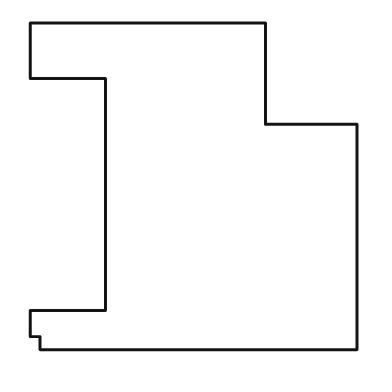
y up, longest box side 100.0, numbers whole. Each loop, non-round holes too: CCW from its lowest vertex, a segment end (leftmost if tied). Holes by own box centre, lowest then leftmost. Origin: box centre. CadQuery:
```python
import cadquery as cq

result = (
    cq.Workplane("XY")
    .moveTo(-47.0, -50.0)
    .lineTo(50.0, -50.0)
    .lineTo(50.0, 19.0)
    .lineTo(22.0, 19.0)
    .lineTo(22.0, 50.0)
    .lineTo(-50.0, 50.0)
    .lineTo(-50.0, 33.0)
    .lineTo(-27.0, 33.0)
    .lineTo(-27.0, -38.0)
    .lineTo(-50.0, -38.0)
    .lineTo(-50.0, -46.0)
    .lineTo(-47.0, -46.0)
    .close()
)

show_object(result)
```